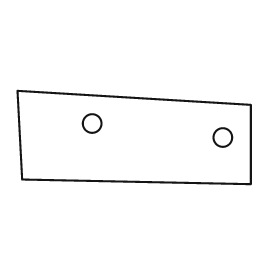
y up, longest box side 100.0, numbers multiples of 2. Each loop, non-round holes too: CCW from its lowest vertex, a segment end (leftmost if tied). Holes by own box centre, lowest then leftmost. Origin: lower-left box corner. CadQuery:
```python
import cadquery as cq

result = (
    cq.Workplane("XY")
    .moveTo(100.0, 0.0)
    .lineTo(100.0, 34.0)
    .lineTo(0.0, 40.0)
    .lineTo(2.0, 2.0)
    .close()
    .moveTo(88.0, 20.0)
    .circle(4.0)
    .moveTo(32.0, 26.0)
    .circle(4.0)
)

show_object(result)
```